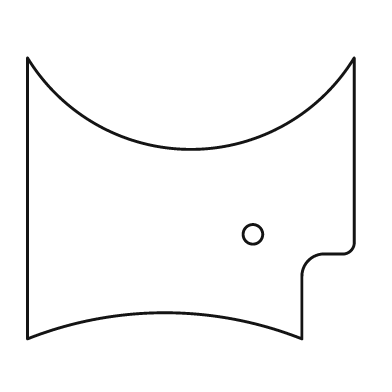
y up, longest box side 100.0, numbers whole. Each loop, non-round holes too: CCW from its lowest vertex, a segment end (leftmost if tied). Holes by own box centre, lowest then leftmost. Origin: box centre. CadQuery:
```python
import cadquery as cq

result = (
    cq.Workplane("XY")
    .moveTo(-50.0, -43.0)
    .threePointArc((-8.0, -35.0), (34.0, -43.0))
    .lineTo(34.0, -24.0)
    .threePointArc((36.0, -19.0), (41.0, -17.0))
    .lineTo(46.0, -17.0)
    .threePointArc((49.0, -16.0), (50.0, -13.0))
    .lineTo(50.0, 43.0)
    .threePointArc((0.0, 15.0), (-50.0, 43.0))
    .close()
    .moveTo(19.0, -11.0)
    .circle(3.0)
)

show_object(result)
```